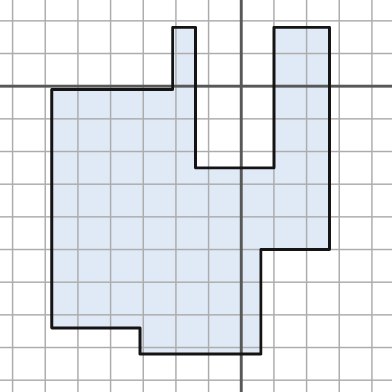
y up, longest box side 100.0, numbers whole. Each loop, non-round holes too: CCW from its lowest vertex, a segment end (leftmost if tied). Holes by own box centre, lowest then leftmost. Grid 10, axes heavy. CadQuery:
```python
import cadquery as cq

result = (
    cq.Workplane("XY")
    .moveTo(-31.0, -82.0)
    .lineTo(6.0, -82.0)
    .lineTo(6.0, -50.0)
    .lineTo(27.0, -50.0)
    .lineTo(27.0, 18.0)
    .lineTo(10.0, 18.0)
    .lineTo(10.0, -25.0)
    .lineTo(-14.0, -25.0)
    .lineTo(-14.0, 18.0)
    .lineTo(-21.0, 18.0)
    .lineTo(-21.0, -1.0)
    .lineTo(-58.0, -1.0)
    .lineTo(-58.0, -74.0)
    .lineTo(-31.0, -74.0)
    .close()
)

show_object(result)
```